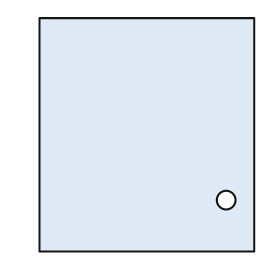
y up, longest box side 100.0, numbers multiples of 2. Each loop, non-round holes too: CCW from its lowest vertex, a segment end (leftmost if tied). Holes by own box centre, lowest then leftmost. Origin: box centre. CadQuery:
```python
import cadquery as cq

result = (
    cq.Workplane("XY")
    .moveTo(-46.0, -50.0)
    .lineTo(46.0, -50.0)
    .lineTo(46.0, 50.0)
    .lineTo(-46.0, 50.0)
    .close()
    .moveTo(34.0, -28.0)
    .circle(4.0)
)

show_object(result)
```